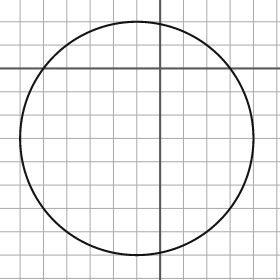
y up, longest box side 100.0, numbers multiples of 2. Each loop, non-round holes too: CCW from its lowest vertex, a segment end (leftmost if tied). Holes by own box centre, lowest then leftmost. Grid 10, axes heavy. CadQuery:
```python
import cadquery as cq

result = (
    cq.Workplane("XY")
    .moveTo(-10.0, -30.0)
    .circle(50.0)
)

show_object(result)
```